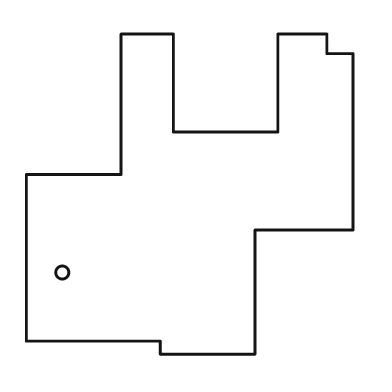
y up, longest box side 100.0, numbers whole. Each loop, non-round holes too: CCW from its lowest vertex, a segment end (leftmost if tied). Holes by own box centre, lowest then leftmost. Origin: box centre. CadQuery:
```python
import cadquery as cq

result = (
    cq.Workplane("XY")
    .moveTo(-9.0, -49.0)
    .lineTo(20.0, -49.0)
    .lineTo(20.0, -11.0)
    .lineTo(50.0, -11.0)
    .lineTo(50.0, 43.0)
    .lineTo(42.0, 43.0)
    .lineTo(42.0, 49.0)
    .lineTo(27.0, 49.0)
    .lineTo(27.0, 19.0)
    .lineTo(-5.0, 19.0)
    .lineTo(-5.0, 49.0)
    .lineTo(-21.0, 49.0)
    .lineTo(-21.0, 6.0)
    .lineTo(-50.0, 6.0)
    .lineTo(-50.0, -45.0)
    .lineTo(-9.0, -45.0)
    .close()
    .moveTo(-39.0, -24.0)
    .circle(2.0)
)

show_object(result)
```